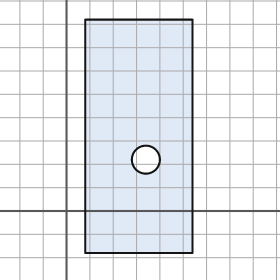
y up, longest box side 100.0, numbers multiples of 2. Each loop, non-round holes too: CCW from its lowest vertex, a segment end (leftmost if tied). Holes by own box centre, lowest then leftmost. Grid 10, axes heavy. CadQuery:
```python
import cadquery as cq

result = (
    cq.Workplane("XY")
    .moveTo(8.0, -18.0)
    .lineTo(54.0, -18.0)
    .lineTo(54.0, 82.0)
    .lineTo(8.0, 82.0)
    .close()
    .moveTo(34.0, 22.0)
    .circle(6.0)
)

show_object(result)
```